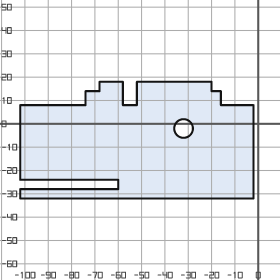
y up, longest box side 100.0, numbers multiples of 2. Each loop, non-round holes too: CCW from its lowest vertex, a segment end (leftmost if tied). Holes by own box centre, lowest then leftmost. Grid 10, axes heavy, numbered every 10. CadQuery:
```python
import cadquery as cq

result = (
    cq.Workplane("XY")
    .moveTo(-102.0, -32.0)
    .lineTo(-2.0, -32.0)
    .lineTo(-2.0, 8.0)
    .lineTo(-16.0, 8.0)
    .lineTo(-16.0, 14.0)
    .lineTo(-20.0, 14.0)
    .lineTo(-20.0, 18.0)
    .lineTo(-52.0, 18.0)
    .lineTo(-52.0, 8.0)
    .lineTo(-58.0, 8.0)
    .lineTo(-58.0, 18.0)
    .lineTo(-68.0, 18.0)
    .lineTo(-68.0, 14.0)
    .lineTo(-74.0, 14.0)
    .lineTo(-74.0, 8.0)
    .lineTo(-102.0, 8.0)
    .lineTo(-102.0, -24.0)
    .lineTo(-60.0, -24.0)
    .lineTo(-60.0, -28.0)
    .lineTo(-102.0, -28.0)
    .close()
    .moveTo(-32.0, -2.0)
    .circle(4.0)
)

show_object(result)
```